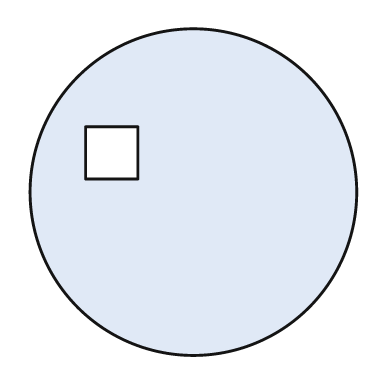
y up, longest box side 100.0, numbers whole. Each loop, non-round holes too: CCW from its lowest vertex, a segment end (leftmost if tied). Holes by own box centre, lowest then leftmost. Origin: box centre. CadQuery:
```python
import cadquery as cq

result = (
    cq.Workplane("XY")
    .moveTo(0.0, 0.0)
    .circle(50.0)
    .moveTo(-33.0, 4.0)
    .lineTo(-17.0, 4.0)
    .lineTo(-17.0, 20.0)
    .lineTo(-33.0, 20.0)
    .close()
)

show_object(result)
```